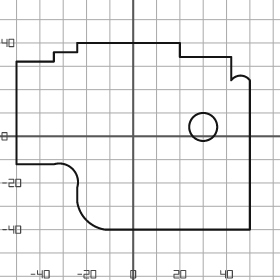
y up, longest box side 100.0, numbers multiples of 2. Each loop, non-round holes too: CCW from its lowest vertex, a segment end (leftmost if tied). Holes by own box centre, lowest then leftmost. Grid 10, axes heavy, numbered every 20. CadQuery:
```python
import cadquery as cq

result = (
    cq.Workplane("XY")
    .moveTo(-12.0, -40.0)
    .lineTo(50.0, -40.0)
    .lineTo(50.0, 24.0)
    .threePointArc((46.0, 26.0), (42.0, 24.0))
    .lineTo(42.0, 34.0)
    .lineTo(20.0, 34.0)
    .lineTo(20.0, 40.0)
    .lineTo(-24.0, 40.0)
    .lineTo(-24.0, 36.0)
    .lineTo(-34.0, 36.0)
    .lineTo(-34.0, 32.0)
    .lineTo(-50.0, 32.0)
    .lineTo(-50.0, -12.0)
    .lineTo(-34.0, -12.0)
    .threePointArc((-26.0, -14.0), (-24.0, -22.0))
    .lineTo(-24.0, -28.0)
    .threePointArc((-20.0, -36.0), (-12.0, -40.0))
    .close()
    .moveTo(30.0, 4.0)
    .circle(6.0)
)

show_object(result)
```